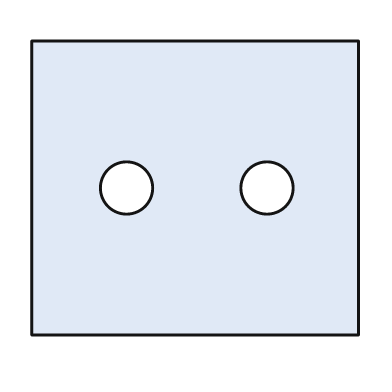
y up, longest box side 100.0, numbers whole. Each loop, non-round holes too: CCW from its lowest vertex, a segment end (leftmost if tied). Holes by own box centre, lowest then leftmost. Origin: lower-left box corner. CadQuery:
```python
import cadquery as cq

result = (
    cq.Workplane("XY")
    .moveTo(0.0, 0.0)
    .lineTo(100.0, 0.0)
    .lineTo(100.0, 90.0)
    .lineTo(0.0, 90.0)
    .close()
    .moveTo(29.0, 45.0)
    .circle(8.0)
    .moveTo(72.0, 45.0)
    .circle(8.0)
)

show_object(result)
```